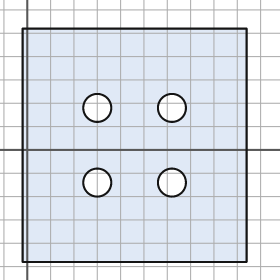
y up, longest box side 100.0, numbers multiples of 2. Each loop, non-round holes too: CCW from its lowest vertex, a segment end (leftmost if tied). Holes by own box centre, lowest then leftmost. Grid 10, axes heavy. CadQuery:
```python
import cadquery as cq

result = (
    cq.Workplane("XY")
    .moveTo(-2.0, -48.0)
    .lineTo(94.0, -48.0)
    .lineTo(94.0, 52.0)
    .lineTo(-2.0, 52.0)
    .close()
    .moveTo(30.0, -14.0)
    .circle(6.0)
    .moveTo(62.0, -14.0)
    .circle(6.0)
    .moveTo(30.0, 18.0)
    .circle(6.0)
    .moveTo(62.0, 18.0)
    .circle(6.0)
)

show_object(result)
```